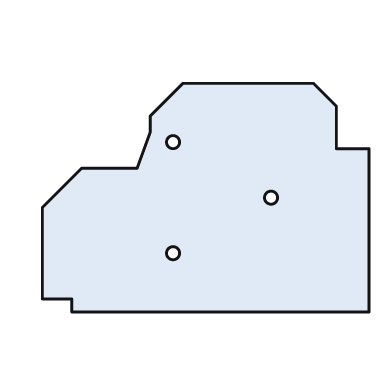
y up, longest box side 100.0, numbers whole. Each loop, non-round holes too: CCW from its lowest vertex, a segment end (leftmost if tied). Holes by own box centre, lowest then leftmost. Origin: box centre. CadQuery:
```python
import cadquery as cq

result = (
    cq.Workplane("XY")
    .moveTo(-41.0, -35.0)
    .lineTo(50.0, -35.0)
    .lineTo(50.0, 15.0)
    .lineTo(40.0, 15.0)
    .lineTo(40.0, 28.0)
    .lineTo(33.0, 35.0)
    .lineTo(-7.0, 35.0)
    .lineTo(-17.0, 25.0)
    .lineTo(-17.0, 20.0)
    .lineTo(-21.0, 9.0)
    .lineTo(-38.0, 9.0)
    .lineTo(-50.0, -3.0)
    .lineTo(-50.0, -31.0)
    .lineTo(-41.0, -31.0)
    .close()
    .moveTo(-10.0, -17.0)
    .circle(2.0)
    .moveTo(20.0, 0.0)
    .circle(2.0)
    .moveTo(-10.0, 17.0)
    .circle(2.0)
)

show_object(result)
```